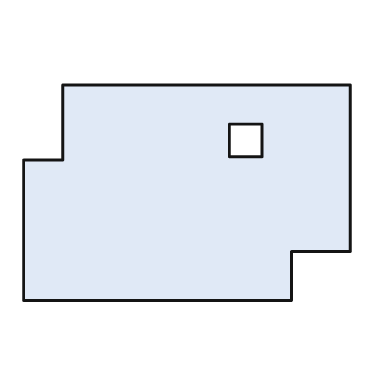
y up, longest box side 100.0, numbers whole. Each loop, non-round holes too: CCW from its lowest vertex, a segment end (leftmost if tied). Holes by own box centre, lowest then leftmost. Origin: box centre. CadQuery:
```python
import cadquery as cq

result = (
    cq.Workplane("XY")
    .moveTo(-50.0, -33.0)
    .lineTo(32.0, -33.0)
    .lineTo(32.0, -18.0)
    .lineTo(50.0, -18.0)
    .lineTo(50.0, 33.0)
    .lineTo(-38.0, 33.0)
    .lineTo(-38.0, 10.0)
    .lineTo(-50.0, 10.0)
    .close()
    .moveTo(13.0, 11.0)
    .lineTo(23.0, 11.0)
    .lineTo(23.0, 21.0)
    .lineTo(13.0, 21.0)
    .close()
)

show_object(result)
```